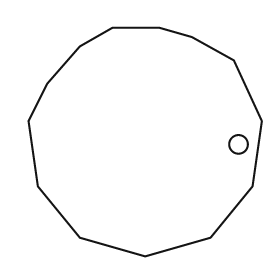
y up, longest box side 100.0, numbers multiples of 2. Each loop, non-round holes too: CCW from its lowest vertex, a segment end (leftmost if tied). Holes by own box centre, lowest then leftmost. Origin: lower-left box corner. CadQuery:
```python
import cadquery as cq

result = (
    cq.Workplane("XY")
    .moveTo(50.0, 0.0)
    .lineTo(78.0, 8.0)
    .lineTo(96.0, 30.0)
    .lineTo(100.0, 58.0)
    .lineTo(88.0, 84.0)
    .lineTo(70.0, 94.0)
    .lineTo(56.0, 98.0)
    .lineTo(36.0, 98.0)
    .lineTo(22.0, 90.0)
    .lineTo(8.0, 74.0)
    .lineTo(0.0, 58.0)
    .lineTo(4.0, 30.0)
    .lineTo(22.0, 8.0)
    .close()
    .moveTo(90.0, 48.0)
    .circle(4.0)
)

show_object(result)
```